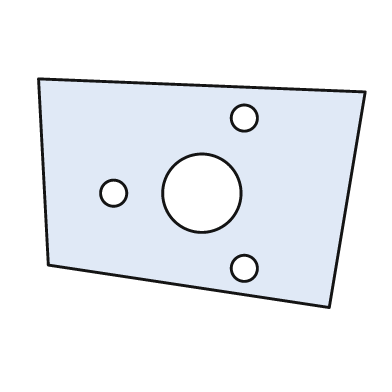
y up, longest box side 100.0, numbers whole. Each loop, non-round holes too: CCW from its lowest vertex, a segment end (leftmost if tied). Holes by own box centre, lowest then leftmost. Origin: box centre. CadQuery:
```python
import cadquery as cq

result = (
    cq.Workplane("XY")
    .moveTo(39.0, -35.0)
    .lineTo(50.0, 31.0)
    .lineTo(-50.0, 35.0)
    .lineTo(-47.0, -22.0)
    .close()
    .moveTo(13.0, -23.0)
    .circle(4.0)
    .moveTo(-27.0, 0.0)
    .circle(4.0)
    .moveTo(0.0, 0.0)
    .circle(12.0)
    .moveTo(13.0, 23.0)
    .circle(4.0)
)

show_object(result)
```